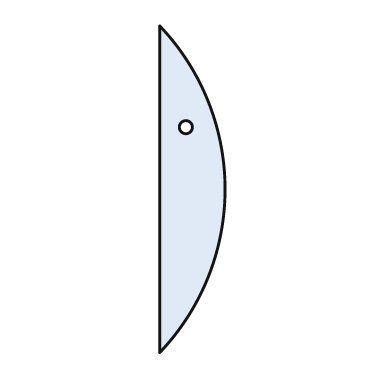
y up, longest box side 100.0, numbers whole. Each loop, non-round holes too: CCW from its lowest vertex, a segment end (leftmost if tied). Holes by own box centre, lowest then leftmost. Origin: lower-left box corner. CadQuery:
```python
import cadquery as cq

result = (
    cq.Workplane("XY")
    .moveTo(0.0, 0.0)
    .threePointArc((20.0, 50.0), (0.0, 100.0))
    .close()
    .moveTo(8.0, 69.0)
    .circle(2.0)
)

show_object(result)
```